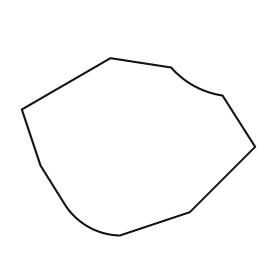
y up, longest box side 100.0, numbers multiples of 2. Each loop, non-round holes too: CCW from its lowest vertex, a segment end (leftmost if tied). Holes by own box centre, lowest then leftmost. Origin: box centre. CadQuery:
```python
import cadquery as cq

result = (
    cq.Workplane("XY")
    .moveTo(-8.0, -38.0)
    .lineTo(22.0, -28.0)
    .lineTo(50.0, 0.0)
    .lineTo(36.0, 22.0)
    .threePointArc((24.0, 26.0), (14.0, 34.0))
    .lineTo(-12.0, 38.0)
    .lineTo(-50.0, 16.0)
    .lineTo(-42.0, -8.0)
    .lineTo(-32.0, -24.0)
    .threePointArc((-22.0, -34.0), (-8.0, -38.0))
    .close()
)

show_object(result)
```